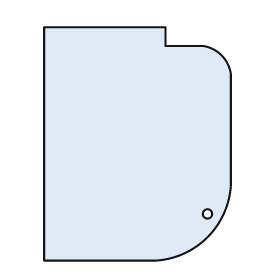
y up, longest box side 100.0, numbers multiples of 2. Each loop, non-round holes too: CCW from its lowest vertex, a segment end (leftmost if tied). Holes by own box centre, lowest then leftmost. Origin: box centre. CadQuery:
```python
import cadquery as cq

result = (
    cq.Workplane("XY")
    .moveTo(-40.0, -50.0)
    .lineTo(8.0, -50.0)
    .threePointArc((30.0, -40.0), (40.0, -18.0))
    .lineTo(40.0, 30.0)
    .threePointArc((36.0, 38.0), (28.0, 42.0))
    .lineTo(12.0, 42.0)
    .lineTo(12.0, 50.0)
    .lineTo(-40.0, 50.0)
    .close()
    .moveTo(30.0, -30.0)
    .circle(2.0)
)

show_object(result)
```